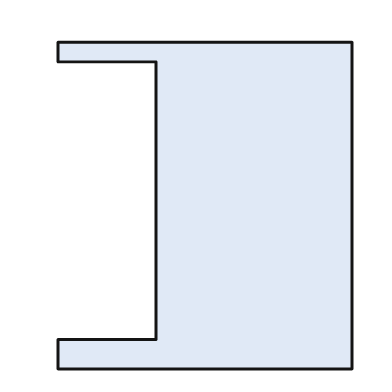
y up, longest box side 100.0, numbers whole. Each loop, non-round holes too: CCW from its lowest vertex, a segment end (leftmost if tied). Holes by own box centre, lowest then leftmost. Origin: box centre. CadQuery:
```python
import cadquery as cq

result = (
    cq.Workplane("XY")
    .moveTo(-45.0, -50.0)
    .lineTo(45.0, -50.0)
    .lineTo(45.0, 50.0)
    .lineTo(-45.0, 50.0)
    .lineTo(-45.0, 44.0)
    .lineTo(-15.0, 44.0)
    .lineTo(-15.0, -41.0)
    .lineTo(-45.0, -41.0)
    .close()
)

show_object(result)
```